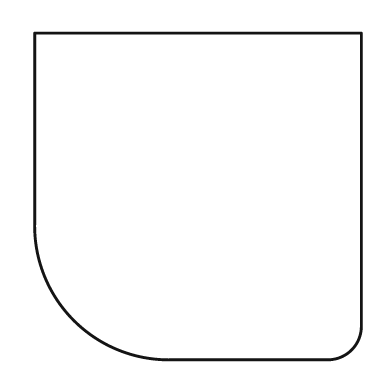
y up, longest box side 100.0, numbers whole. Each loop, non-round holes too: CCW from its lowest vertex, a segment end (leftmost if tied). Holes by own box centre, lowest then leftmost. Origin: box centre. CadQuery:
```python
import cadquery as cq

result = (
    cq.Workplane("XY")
    .moveTo(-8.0, -50.0)
    .lineTo(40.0, -50.0)
    .threePointArc((47.0, -47.0), (50.0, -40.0))
    .lineTo(50.0, 50.0)
    .lineTo(-50.0, 50.0)
    .lineTo(-50.0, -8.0)
    .threePointArc((-38.0, -38.0), (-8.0, -50.0))
    .close()
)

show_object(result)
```